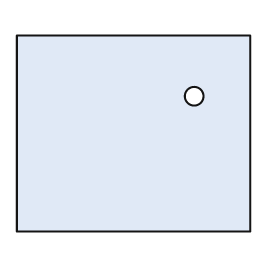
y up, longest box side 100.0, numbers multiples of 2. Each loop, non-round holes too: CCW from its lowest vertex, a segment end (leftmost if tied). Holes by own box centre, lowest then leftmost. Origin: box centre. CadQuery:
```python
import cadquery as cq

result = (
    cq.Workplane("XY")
    .moveTo(-50.0, -42.0)
    .lineTo(50.0, -42.0)
    .lineTo(50.0, 42.0)
    .lineTo(-50.0, 42.0)
    .close()
    .moveTo(26.0, 16.0)
    .circle(4.0)
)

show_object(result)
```